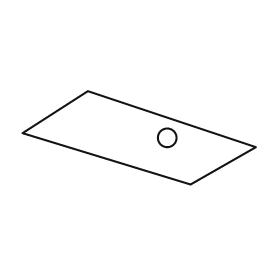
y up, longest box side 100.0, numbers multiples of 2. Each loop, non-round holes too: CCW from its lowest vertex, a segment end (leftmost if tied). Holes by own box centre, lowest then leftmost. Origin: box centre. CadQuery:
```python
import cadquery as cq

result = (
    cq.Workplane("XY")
    .moveTo(22.0, -20.0)
    .lineTo(50.0, -4.0)
    .lineTo(-22.0, 20.0)
    .lineTo(-50.0, 2.0)
    .close()
    .moveTo(12.0, 0.0)
    .circle(4.0)
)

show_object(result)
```